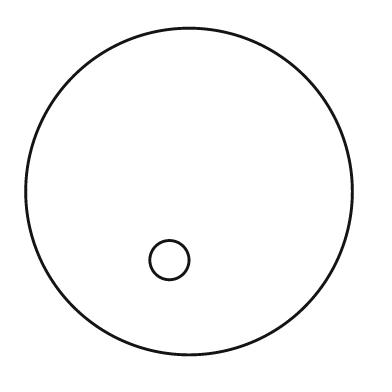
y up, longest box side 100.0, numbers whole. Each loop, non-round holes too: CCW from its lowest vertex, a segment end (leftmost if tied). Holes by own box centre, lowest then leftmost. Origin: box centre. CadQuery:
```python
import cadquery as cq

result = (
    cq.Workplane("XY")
    .moveTo(0.0, 0.0)
    .circle(50.0)
    .moveTo(-6.0, -21.0)
    .circle(6.0)
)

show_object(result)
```